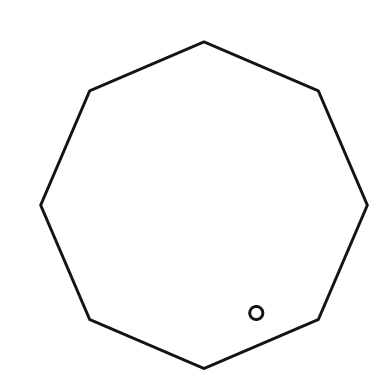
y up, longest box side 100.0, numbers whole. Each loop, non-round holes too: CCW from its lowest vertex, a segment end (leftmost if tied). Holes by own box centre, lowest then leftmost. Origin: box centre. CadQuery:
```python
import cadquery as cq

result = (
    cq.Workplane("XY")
    .moveTo(0.0, -50.0)
    .lineTo(35.0, -35.0)
    .lineTo(50.0, 0.0)
    .lineTo(35.0, 35.0)
    .lineTo(0.0, 50.0)
    .lineTo(-35.0, 35.0)
    .lineTo(-50.0, 0.0)
    .lineTo(-35.0, -35.0)
    .close()
    .moveTo(16.0, -33.0)
    .circle(2.0)
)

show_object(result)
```